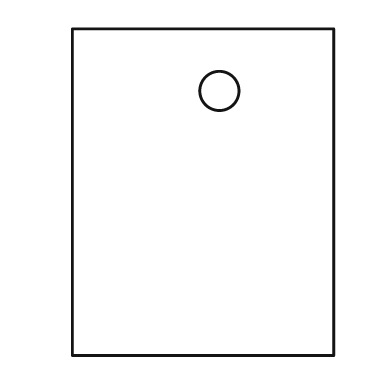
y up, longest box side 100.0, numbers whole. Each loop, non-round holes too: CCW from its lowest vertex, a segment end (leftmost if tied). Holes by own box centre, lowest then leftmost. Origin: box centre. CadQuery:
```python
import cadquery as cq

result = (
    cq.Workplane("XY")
    .moveTo(-40.0, -50.0)
    .lineTo(40.0, -50.0)
    .lineTo(40.0, 50.0)
    .lineTo(-40.0, 50.0)
    .close()
    .moveTo(5.0, 31.0)
    .circle(6.0)
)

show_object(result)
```